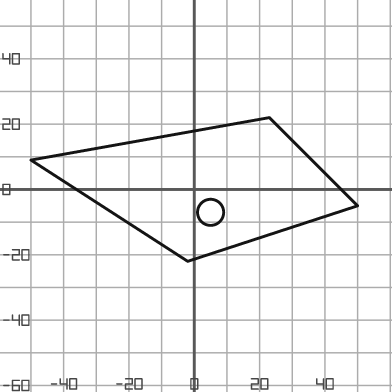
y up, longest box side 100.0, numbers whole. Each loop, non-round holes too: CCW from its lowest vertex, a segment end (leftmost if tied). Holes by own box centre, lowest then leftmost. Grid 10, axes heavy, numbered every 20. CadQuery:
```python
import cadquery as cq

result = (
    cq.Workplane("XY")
    .moveTo(-2.0, -22.0)
    .lineTo(50.0, -5.0)
    .lineTo(23.0, 22.0)
    .lineTo(-50.0, 9.0)
    .close()
    .moveTo(5.0, -7.0)
    .circle(4.0)
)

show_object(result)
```